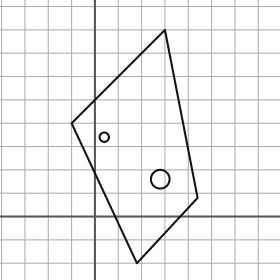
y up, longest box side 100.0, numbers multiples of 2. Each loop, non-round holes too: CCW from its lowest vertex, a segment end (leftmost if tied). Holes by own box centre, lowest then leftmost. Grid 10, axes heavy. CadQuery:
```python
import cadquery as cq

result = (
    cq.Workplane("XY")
    .moveTo(18.0, -20.0)
    .lineTo(44.0, 8.0)
    .lineTo(30.0, 80.0)
    .lineTo(-10.0, 40.0)
    .close()
    .moveTo(28.0, 16.0)
    .circle(4.0)
    .moveTo(4.0, 34.0)
    .circle(2.0)
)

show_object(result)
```